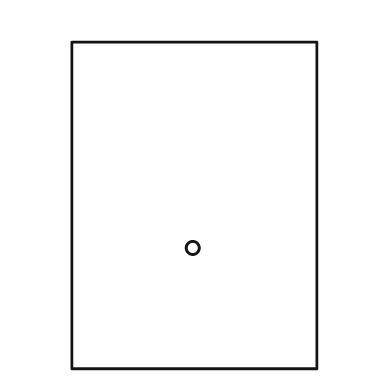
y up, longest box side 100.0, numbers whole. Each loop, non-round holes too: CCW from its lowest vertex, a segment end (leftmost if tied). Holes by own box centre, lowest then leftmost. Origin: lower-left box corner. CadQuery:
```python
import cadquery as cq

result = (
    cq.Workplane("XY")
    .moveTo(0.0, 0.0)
    .lineTo(75.0, 0.0)
    .lineTo(75.0, 100.0)
    .lineTo(0.0, 100.0)
    .close()
    .moveTo(37.0, 37.0)
    .circle(2.0)
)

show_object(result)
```